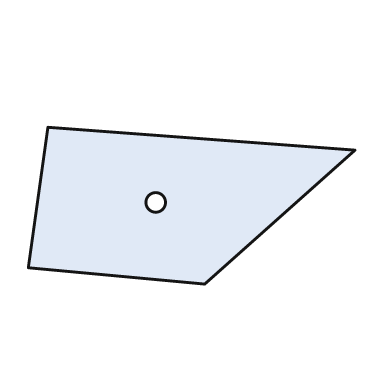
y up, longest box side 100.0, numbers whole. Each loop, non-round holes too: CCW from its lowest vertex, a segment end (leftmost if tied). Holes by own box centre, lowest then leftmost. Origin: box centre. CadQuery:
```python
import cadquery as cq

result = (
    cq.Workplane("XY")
    .moveTo(4.0, -24.0)
    .lineTo(50.0, 17.0)
    .lineTo(-44.0, 24.0)
    .lineTo(-50.0, -19.0)
    .close()
    .moveTo(-11.0, 1.0)
    .circle(3.0)
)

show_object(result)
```